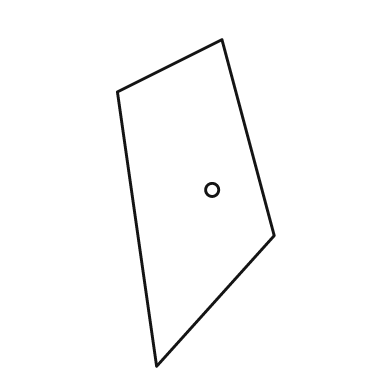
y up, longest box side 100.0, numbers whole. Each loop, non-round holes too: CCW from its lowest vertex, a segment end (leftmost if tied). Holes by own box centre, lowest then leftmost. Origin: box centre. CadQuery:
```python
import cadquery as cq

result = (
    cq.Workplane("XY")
    .moveTo(-12.0, -50.0)
    .lineTo(24.0, -10.0)
    .lineTo(8.0, 50.0)
    .lineTo(-24.0, 34.0)
    .close()
    .moveTo(5.0, 4.0)
    .circle(2.0)
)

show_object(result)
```